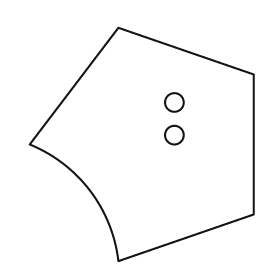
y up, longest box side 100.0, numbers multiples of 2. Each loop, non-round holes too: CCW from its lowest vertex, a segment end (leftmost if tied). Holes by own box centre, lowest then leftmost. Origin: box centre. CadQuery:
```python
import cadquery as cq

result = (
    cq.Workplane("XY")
    .moveTo(-10.0, -50.0)
    .lineTo(48.0, -30.0)
    .lineTo(48.0, 30.0)
    .lineTo(-10.0, 50.0)
    .lineTo(-48.0, 0.0)
    .threePointArc((-22.0, -20.0), (-10.0, -50.0))
    .close()
    .moveTo(14.0, 4.0)
    .circle(4.0)
    .moveTo(14.0, 18.0)
    .circle(4.0)
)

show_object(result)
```